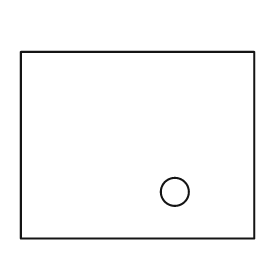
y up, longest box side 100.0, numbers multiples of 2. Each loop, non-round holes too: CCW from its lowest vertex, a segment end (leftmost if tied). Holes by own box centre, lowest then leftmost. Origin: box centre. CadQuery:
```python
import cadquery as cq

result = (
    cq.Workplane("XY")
    .moveTo(-50.0, -40.0)
    .lineTo(50.0, -40.0)
    .lineTo(50.0, 40.0)
    .lineTo(-50.0, 40.0)
    .close()
    .moveTo(16.0, -20.0)
    .circle(6.0)
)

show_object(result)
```